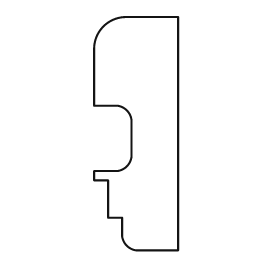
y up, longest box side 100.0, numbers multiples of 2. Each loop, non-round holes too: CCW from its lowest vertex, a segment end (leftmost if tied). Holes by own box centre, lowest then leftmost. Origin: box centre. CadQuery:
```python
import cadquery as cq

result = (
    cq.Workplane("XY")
    .moveTo(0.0, -50.0)
    .lineTo(18.0, -50.0)
    .lineTo(18.0, 50.0)
    .lineTo(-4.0, 50.0)
    .threePointArc((-14.0, 46.0), (-18.0, 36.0))
    .lineTo(-18.0, 12.0)
    .lineTo(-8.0, 12.0)
    .threePointArc((-4.0, 10.0), (-2.0, 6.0))
    .lineTo(-2.0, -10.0)
    .threePointArc((-4.0, -14.0), (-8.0, -16.0))
    .lineTo(-18.0, -16.0)
    .lineTo(-18.0, -20.0)
    .lineTo(-12.0, -20.0)
    .lineTo(-12.0, -36.0)
    .lineTo(-6.0, -36.0)
    .lineTo(-6.0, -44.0)
    .threePointArc((-4.0, -48.0), (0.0, -50.0))
    .close()
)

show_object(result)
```